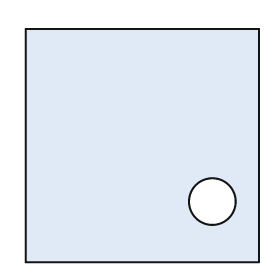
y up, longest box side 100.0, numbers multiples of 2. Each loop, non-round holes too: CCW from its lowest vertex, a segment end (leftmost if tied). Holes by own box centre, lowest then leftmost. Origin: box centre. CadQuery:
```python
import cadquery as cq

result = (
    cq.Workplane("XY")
    .moveTo(-50.0, -50.0)
    .lineTo(50.0, -50.0)
    .lineTo(50.0, 50.0)
    .lineTo(-50.0, 50.0)
    .close()
    .moveTo(30.0, -24.0)
    .circle(10.0)
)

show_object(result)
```